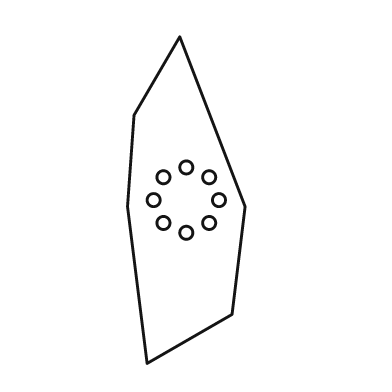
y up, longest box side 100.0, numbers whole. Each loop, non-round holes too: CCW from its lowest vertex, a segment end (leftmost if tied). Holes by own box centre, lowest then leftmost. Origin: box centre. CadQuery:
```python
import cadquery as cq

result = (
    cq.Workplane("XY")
    .moveTo(-12.0, -50.0)
    .lineTo(14.0, -35.0)
    .lineTo(18.0, -2.0)
    .lineTo(-2.0, 50.0)
    .lineTo(-16.0, 26.0)
    .lineTo(-18.0, -2.0)
    .close()
    .moveTo(0.0, -10.0)
    .circle(2.0)
    .moveTo(-7.0, -7.0)
    .circle(2.0)
    .moveTo(7.0, -7.0)
    .circle(2.0)
    .moveTo(-10.0, 0.0)
    .circle(2.0)
    .moveTo(10.0, 0.0)
    .circle(2.0)
    .moveTo(-7.0, 7.0)
    .circle(2.0)
    .moveTo(7.0, 7.0)
    .circle(2.0)
    .moveTo(0.0, 10.0)
    .circle(2.0)
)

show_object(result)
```